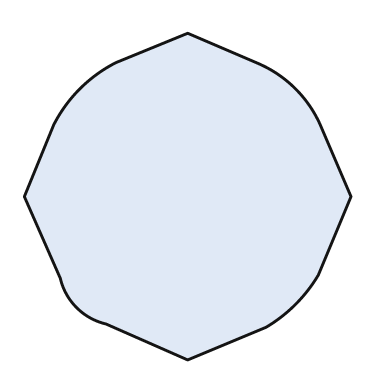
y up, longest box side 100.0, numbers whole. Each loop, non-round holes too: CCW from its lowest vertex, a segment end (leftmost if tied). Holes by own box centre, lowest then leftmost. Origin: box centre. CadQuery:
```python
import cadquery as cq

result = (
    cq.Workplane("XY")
    .moveTo(0.0, -50.0)
    .lineTo(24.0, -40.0)
    .threePointArc((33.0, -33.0), (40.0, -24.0))
    .lineTo(50.0, 0.0)
    .lineTo(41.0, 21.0)
    .threePointArc((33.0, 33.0), (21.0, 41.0))
    .lineTo(0.0, 50.0)
    .lineTo(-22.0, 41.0)
    .threePointArc((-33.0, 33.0), (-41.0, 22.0))
    .lineTo(-50.0, 0.0)
    .lineTo(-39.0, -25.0)
    .threePointArc((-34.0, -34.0), (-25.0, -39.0))
    .close()
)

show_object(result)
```